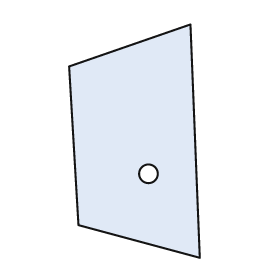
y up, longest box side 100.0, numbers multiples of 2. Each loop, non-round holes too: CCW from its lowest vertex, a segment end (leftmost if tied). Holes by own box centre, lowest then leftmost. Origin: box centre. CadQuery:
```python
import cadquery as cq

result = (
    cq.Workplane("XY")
    .moveTo(28.0, -50.0)
    .lineTo(24.0, 50.0)
    .lineTo(-28.0, 32.0)
    .lineTo(-24.0, -36.0)
    .close()
    .moveTo(6.0, -14.0)
    .circle(4.0)
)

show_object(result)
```